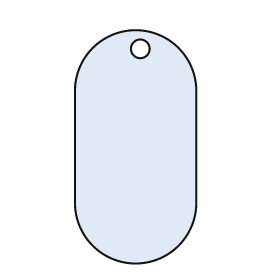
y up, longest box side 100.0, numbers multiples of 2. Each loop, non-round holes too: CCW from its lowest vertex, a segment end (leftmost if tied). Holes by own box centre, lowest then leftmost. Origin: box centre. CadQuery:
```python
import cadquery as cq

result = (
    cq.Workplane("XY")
    .moveTo(-26.0, -24.0)
    .threePointArc((0.0, -50.0), (26.0, -24.0))
    .lineTo(26.0, 24.0)
    .threePointArc((0.0, 50.0), (-26.0, 24.0))
    .close()
    .moveTo(2.0, 42.0)
    .circle(4.0)
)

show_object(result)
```